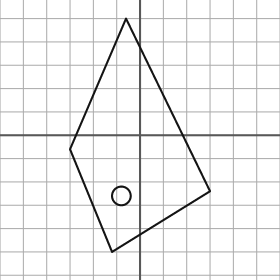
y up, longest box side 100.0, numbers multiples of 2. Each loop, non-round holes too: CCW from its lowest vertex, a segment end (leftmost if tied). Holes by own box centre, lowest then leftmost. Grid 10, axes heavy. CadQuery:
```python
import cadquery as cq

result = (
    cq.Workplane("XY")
    .moveTo(-12.0, -50.0)
    .lineTo(30.0, -24.0)
    .lineTo(-6.0, 50.0)
    .lineTo(-30.0, -6.0)
    .close()
    .moveTo(-8.0, -26.0)
    .circle(4.0)
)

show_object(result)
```